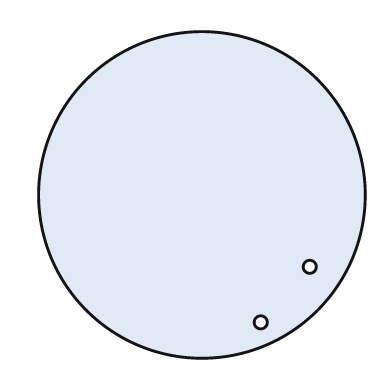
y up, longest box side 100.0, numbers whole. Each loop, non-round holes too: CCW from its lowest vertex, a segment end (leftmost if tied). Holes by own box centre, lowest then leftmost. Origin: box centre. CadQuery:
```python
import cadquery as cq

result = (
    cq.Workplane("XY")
    .moveTo(0.0, 0.0)
    .circle(50.0)
    .moveTo(18.0, -39.0)
    .circle(2.0)
    .moveTo(33.0, -22.0)
    .circle(2.0)
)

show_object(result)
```